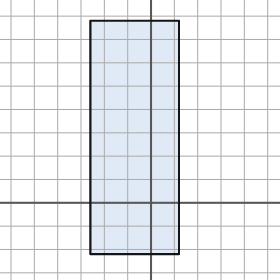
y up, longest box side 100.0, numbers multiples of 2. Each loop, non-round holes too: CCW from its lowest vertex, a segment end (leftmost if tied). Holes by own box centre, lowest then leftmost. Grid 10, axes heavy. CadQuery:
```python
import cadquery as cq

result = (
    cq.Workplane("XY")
    .moveTo(-26.0, -22.0)
    .lineTo(12.0, -22.0)
    .lineTo(12.0, 78.0)
    .lineTo(-26.0, 78.0)
    .close()
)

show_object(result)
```